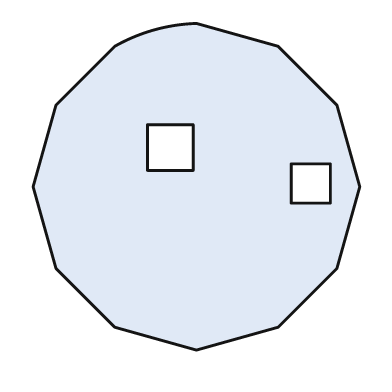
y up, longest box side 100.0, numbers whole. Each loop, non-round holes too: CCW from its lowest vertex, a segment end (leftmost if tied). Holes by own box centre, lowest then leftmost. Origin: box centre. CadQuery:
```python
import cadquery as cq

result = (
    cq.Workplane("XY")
    .moveTo(0.0, -50.0)
    .lineTo(25.0, -43.0)
    .lineTo(43.0, -25.0)
    .lineTo(50.0, 0.0)
    .lineTo(43.0, 25.0)
    .lineTo(25.0, 43.0)
    .lineTo(0.0, 50.0)
    .threePointArc((-13.0, 48.0), (-25.0, 43.0))
    .lineTo(-43.0, 25.0)
    .lineTo(-50.0, 0.0)
    .lineTo(-43.0, -25.0)
    .lineTo(-25.0, -43.0)
    .close()
    .moveTo(29.0, -5.0)
    .lineTo(41.0, -5.0)
    .lineTo(41.0, 7.0)
    .lineTo(29.0, 7.0)
    .close()
    .moveTo(-15.0, 5.0)
    .lineTo(-1.0, 5.0)
    .lineTo(-1.0, 19.0)
    .lineTo(-15.0, 19.0)
    .close()
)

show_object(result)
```